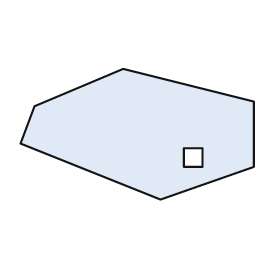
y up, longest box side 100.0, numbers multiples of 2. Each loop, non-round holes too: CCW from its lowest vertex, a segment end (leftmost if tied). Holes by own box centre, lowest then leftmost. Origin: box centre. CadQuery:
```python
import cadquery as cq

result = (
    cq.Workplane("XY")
    .moveTo(10.0, -28.0)
    .lineTo(50.0, -14.0)
    .lineTo(50.0, 14.0)
    .lineTo(-6.0, 28.0)
    .lineTo(-44.0, 12.0)
    .lineTo(-50.0, -4.0)
    .close()
    .moveTo(20.0, -14.0)
    .lineTo(28.0, -14.0)
    .lineTo(28.0, -6.0)
    .lineTo(20.0, -6.0)
    .close()
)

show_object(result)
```